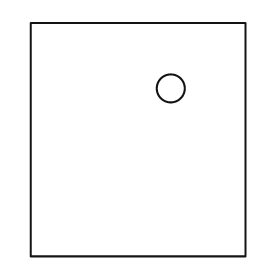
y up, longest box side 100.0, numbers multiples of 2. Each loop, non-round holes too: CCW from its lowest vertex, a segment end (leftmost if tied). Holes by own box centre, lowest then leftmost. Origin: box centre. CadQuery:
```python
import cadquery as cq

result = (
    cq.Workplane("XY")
    .moveTo(-46.0, -50.0)
    .lineTo(46.0, -50.0)
    .lineTo(46.0, 50.0)
    .lineTo(-46.0, 50.0)
    .close()
    .moveTo(14.0, 22.0)
    .circle(6.0)
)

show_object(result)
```